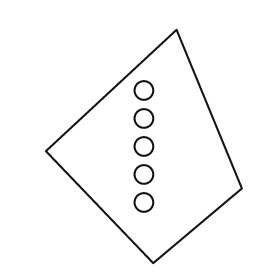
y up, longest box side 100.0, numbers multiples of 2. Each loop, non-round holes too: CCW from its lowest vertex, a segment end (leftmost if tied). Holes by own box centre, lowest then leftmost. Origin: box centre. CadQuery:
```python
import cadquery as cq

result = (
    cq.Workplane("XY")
    .moveTo(4.0, -50.0)
    .lineTo(42.0, -18.0)
    .lineTo(14.0, 50.0)
    .lineTo(-42.0, -2.0)
    .close()
    .moveTo(0.0, -24.0)
    .circle(4.0)
    .moveTo(0.0, -12.0)
    .circle(4.0)
    .moveTo(0.0, 0.0)
    .circle(4.0)
    .moveTo(0.0, 12.0)
    .circle(4.0)
    .moveTo(0.0, 24.0)
    .circle(4.0)
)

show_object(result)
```